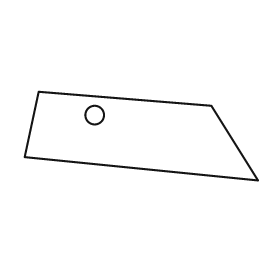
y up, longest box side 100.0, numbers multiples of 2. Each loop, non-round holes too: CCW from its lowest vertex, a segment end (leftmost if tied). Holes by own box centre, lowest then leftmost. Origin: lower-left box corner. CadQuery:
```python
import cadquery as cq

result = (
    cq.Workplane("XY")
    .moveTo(100.0, 0.0)
    .lineTo(80.0, 32.0)
    .lineTo(6.0, 38.0)
    .lineTo(0.0, 10.0)
    .close()
    .moveTo(30.0, 28.0)
    .circle(4.0)
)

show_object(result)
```